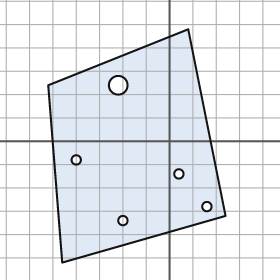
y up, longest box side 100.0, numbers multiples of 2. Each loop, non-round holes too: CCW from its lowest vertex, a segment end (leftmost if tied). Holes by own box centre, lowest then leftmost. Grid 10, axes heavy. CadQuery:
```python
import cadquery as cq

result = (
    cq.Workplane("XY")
    .moveTo(-46.0, -52.0)
    .lineTo(24.0, -32.0)
    .lineTo(8.0, 48.0)
    .lineTo(-52.0, 24.0)
    .close()
    .moveTo(-20.0, -34.0)
    .circle(2.0)
    .moveTo(16.0, -28.0)
    .circle(2.0)
    .moveTo(4.0, -14.0)
    .circle(2.0)
    .moveTo(-40.0, -8.0)
    .circle(2.0)
    .moveTo(-22.0, 24.0)
    .circle(4.0)
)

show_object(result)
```